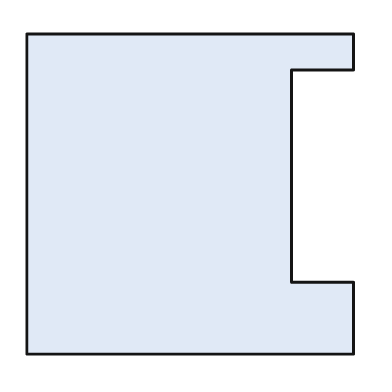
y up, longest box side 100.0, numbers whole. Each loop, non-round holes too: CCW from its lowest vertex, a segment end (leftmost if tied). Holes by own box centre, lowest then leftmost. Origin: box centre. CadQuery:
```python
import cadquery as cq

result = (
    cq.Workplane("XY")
    .moveTo(-50.0, -49.0)
    .lineTo(50.0, -49.0)
    .lineTo(50.0, -27.0)
    .lineTo(31.0, -27.0)
    .lineTo(31.0, 38.0)
    .lineTo(50.0, 38.0)
    .lineTo(50.0, 49.0)
    .lineTo(-50.0, 49.0)
    .close()
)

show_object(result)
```